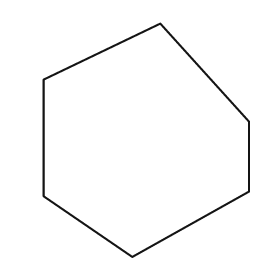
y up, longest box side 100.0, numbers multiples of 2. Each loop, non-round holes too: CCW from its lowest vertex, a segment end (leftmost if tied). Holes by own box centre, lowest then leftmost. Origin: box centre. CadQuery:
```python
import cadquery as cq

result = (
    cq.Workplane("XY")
    .moveTo(-6.0, -50.0)
    .lineTo(44.0, -22.0)
    .lineTo(44.0, 8.0)
    .lineTo(6.0, 50.0)
    .lineTo(-44.0, 26.0)
    .lineTo(-44.0, -24.0)
    .close()
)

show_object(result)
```